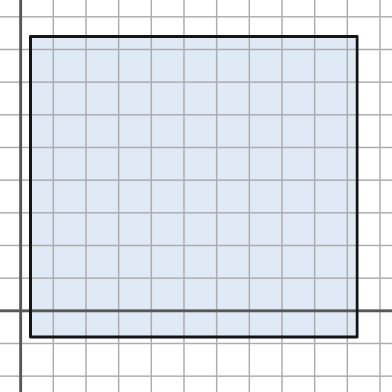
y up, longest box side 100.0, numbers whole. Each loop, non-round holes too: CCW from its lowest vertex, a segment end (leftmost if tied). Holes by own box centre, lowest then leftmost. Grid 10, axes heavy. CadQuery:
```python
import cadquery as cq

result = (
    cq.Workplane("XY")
    .moveTo(3.0, -8.0)
    .lineTo(103.0, -8.0)
    .lineTo(103.0, 84.0)
    .lineTo(3.0, 84.0)
    .close()
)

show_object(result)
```